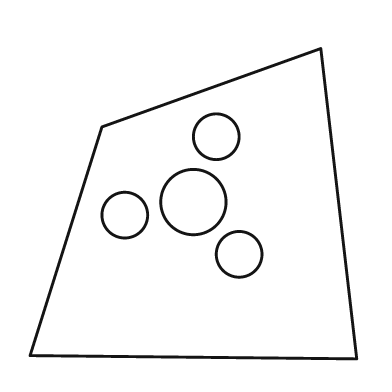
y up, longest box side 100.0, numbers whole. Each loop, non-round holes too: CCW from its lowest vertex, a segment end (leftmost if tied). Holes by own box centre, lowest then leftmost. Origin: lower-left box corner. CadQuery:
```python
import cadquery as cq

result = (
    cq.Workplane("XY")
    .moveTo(100.0, 0.0)
    .lineTo(89.0, 95.0)
    .lineTo(22.0, 71.0)
    .lineTo(0.0, 1.0)
    .close()
    .moveTo(64.0, 32.0)
    .circle(7.0)
    .moveTo(29.0, 44.0)
    .circle(7.0)
    .moveTo(50.0, 48.0)
    .circle(10.0)
    .moveTo(57.0, 68.0)
    .circle(7.0)
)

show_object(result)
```